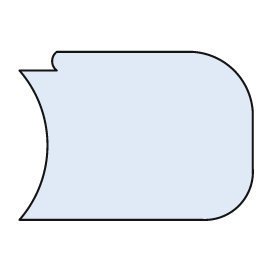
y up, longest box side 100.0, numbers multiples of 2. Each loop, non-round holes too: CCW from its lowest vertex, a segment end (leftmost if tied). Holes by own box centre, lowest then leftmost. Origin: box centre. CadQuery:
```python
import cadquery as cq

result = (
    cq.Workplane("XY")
    .moveTo(-50.0, -36.0)
    .lineTo(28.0, -36.0)
    .threePointArc((44.0, -30.0), (50.0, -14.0))
    .lineTo(50.0, 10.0)
    .threePointArc((42.0, 28.0), (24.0, 36.0))
    .lineTo(-34.0, 36.0)
    .threePointArc((-36.0, 32.0), (-34.0, 28.0))
    .lineTo(-50.0, 28.0)
    .threePointArc((-38.0, -4.0), (-50.0, -36.0))
    .close()
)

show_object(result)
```